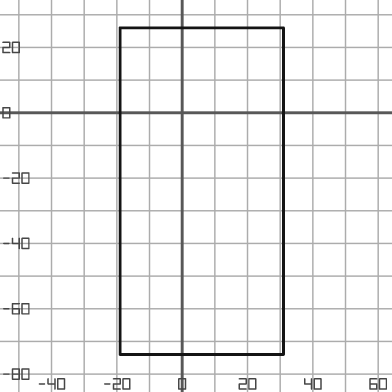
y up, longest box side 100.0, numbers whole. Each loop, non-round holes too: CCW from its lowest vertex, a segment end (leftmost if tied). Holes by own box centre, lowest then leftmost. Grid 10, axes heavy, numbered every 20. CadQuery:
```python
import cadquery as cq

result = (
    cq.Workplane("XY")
    .moveTo(-19.0, -74.0)
    .lineTo(31.0, -74.0)
    .lineTo(31.0, 26.0)
    .lineTo(-19.0, 26.0)
    .close()
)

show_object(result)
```